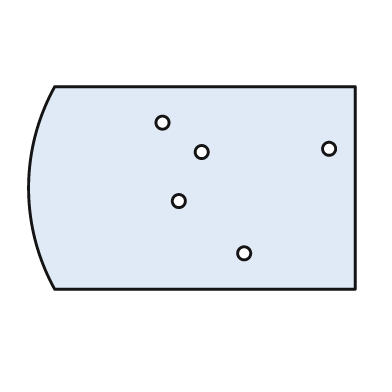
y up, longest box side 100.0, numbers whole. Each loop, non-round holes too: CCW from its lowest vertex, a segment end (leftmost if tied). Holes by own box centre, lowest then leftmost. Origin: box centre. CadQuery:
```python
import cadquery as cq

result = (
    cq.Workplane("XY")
    .moveTo(-42.0, -31.0)
    .lineTo(50.0, -31.0)
    .lineTo(50.0, 31.0)
    .lineTo(-42.0, 31.0)
    .threePointArc((-50.0, 0.0), (-42.0, -31.0))
    .close()
    .moveTo(16.0, -20.0)
    .circle(2.0)
    .moveTo(-4.0, -4.0)
    .circle(2.0)
    .moveTo(3.0, 11.0)
    .circle(2.0)
    .moveTo(42.0, 12.0)
    .circle(2.0)
    .moveTo(-9.0, 20.0)
    .circle(2.0)
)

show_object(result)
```